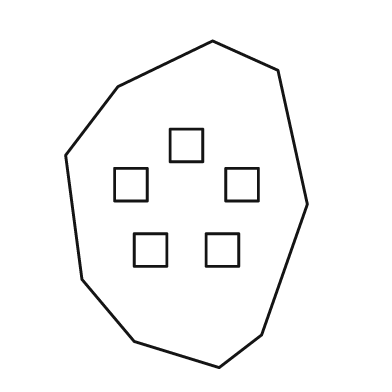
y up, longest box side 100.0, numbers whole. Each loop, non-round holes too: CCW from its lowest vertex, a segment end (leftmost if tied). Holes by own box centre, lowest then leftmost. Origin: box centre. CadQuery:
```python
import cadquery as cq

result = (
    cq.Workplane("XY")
    .moveTo(10.0, -50.0)
    .lineTo(23.0, -40.0)
    .lineTo(37.0, 0.0)
    .lineTo(28.0, 41.0)
    .lineTo(8.0, 50.0)
    .lineTo(-21.0, 36.0)
    .lineTo(-37.0, 15.0)
    .lineTo(-32.0, -23.0)
    .lineTo(-16.0, -42.0)
    .close()
    .moveTo(-16.0, -19.0)
    .lineTo(-6.0, -19.0)
    .lineTo(-6.0, -9.0)
    .lineTo(-16.0, -9.0)
    .close()
    .moveTo(6.0, -19.0)
    .lineTo(16.0, -19.0)
    .lineTo(16.0, -9.0)
    .lineTo(6.0, -9.0)
    .close()
    .moveTo(-22.0, 1.0)
    .lineTo(-12.0, 1.0)
    .lineTo(-12.0, 11.0)
    .lineTo(-22.0, 11.0)
    .close()
    .moveTo(12.0, 1.0)
    .lineTo(22.0, 1.0)
    .lineTo(22.0, 11.0)
    .lineTo(12.0, 11.0)
    .close()
    .moveTo(-5.0, 13.0)
    .lineTo(5.0, 13.0)
    .lineTo(5.0, 23.0)
    .lineTo(-5.0, 23.0)
    .close()
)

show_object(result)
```